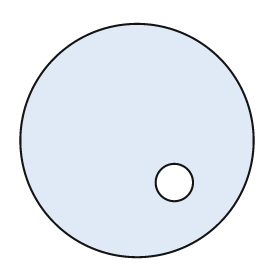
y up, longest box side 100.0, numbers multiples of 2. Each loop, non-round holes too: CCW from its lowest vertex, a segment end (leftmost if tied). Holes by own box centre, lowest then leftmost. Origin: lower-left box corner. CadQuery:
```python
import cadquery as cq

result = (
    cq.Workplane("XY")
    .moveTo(50.0, 50.0)
    .circle(50.0)
    .moveTo(66.0, 32.0)
    .circle(8.0)
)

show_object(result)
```